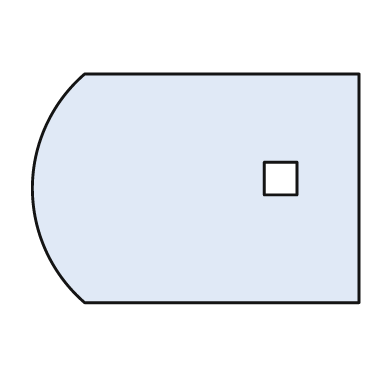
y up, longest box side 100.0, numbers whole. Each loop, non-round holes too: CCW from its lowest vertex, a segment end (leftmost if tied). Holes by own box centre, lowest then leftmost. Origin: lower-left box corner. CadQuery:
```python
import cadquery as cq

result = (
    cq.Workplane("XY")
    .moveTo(16.0, 0.0)
    .lineTo(100.0, 0.0)
    .lineTo(100.0, 70.0)
    .lineTo(16.0, 70.0)
    .threePointArc((0.0, 35.0), (16.0, 0.0))
    .close()
    .moveTo(71.0, 33.0)
    .lineTo(81.0, 33.0)
    .lineTo(81.0, 43.0)
    .lineTo(71.0, 43.0)
    .close()
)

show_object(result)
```